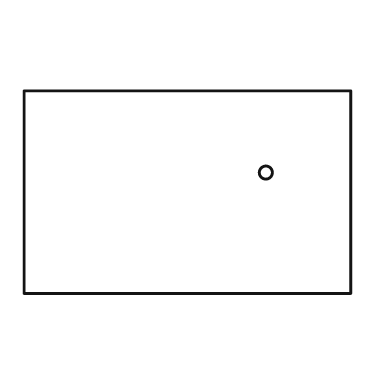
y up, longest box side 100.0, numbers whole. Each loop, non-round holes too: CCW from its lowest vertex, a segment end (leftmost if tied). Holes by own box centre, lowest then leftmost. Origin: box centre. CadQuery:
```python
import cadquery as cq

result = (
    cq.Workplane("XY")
    .moveTo(-50.0, -31.0)
    .lineTo(50.0, -31.0)
    .lineTo(50.0, 31.0)
    .lineTo(-50.0, 31.0)
    .close()
    .moveTo(24.0, 6.0)
    .circle(2.0)
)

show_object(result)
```